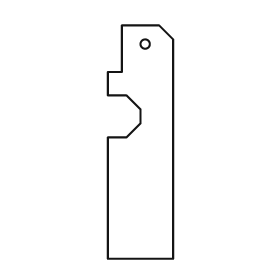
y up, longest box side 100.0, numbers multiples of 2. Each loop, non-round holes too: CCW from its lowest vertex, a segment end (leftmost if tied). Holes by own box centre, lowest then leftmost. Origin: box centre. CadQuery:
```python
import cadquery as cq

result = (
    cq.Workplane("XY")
    .moveTo(-14.0, -50.0)
    .lineTo(14.0, -50.0)
    .lineTo(14.0, 44.0)
    .lineTo(8.0, 50.0)
    .lineTo(-8.0, 50.0)
    .lineTo(-8.0, 30.0)
    .lineTo(-14.0, 30.0)
    .lineTo(-14.0, 20.0)
    .lineTo(-6.0, 20.0)
    .lineTo(0.0, 14.0)
    .lineTo(0.0, 8.0)
    .lineTo(-6.0, 2.0)
    .lineTo(-14.0, 2.0)
    .close()
    .moveTo(2.0, 42.0)
    .circle(2.0)
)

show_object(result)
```